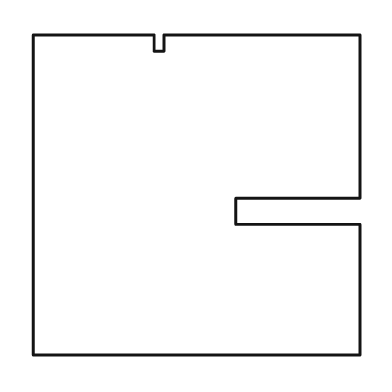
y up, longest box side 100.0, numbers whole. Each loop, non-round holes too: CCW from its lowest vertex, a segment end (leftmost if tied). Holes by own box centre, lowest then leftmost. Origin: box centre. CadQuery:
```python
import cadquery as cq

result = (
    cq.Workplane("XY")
    .moveTo(-50.0, -49.0)
    .lineTo(50.0, -49.0)
    .lineTo(50.0, -9.0)
    .lineTo(12.0, -9.0)
    .lineTo(12.0, -1.0)
    .lineTo(50.0, -1.0)
    .lineTo(50.0, 49.0)
    .lineTo(-10.0, 49.0)
    .lineTo(-10.0, 44.0)
    .lineTo(-13.0, 44.0)
    .lineTo(-13.0, 49.0)
    .lineTo(-50.0, 49.0)
    .close()
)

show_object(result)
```